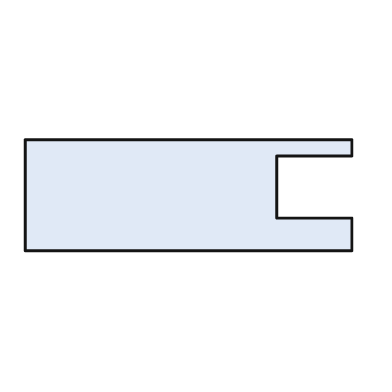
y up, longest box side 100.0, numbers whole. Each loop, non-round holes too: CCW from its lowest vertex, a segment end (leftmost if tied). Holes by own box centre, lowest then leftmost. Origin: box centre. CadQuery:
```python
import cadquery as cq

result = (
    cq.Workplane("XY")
    .moveTo(-50.0, -17.0)
    .lineTo(50.0, -17.0)
    .lineTo(50.0, -7.0)
    .lineTo(27.0, -7.0)
    .lineTo(27.0, 12.0)
    .lineTo(50.0, 12.0)
    .lineTo(50.0, 17.0)
    .lineTo(-50.0, 17.0)
    .close()
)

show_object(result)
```